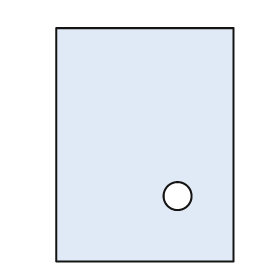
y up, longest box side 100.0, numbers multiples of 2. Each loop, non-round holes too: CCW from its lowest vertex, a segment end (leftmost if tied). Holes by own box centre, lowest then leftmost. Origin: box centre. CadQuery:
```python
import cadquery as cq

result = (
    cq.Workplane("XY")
    .moveTo(-38.0, -50.0)
    .lineTo(38.0, -50.0)
    .lineTo(38.0, 50.0)
    .lineTo(-38.0, 50.0)
    .close()
    .moveTo(14.0, -22.0)
    .circle(6.0)
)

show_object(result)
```